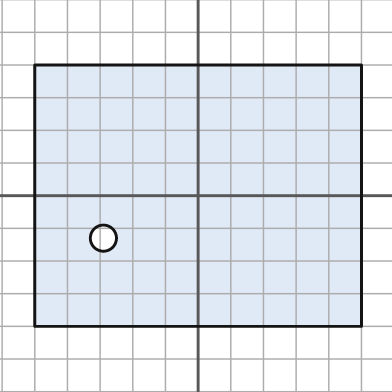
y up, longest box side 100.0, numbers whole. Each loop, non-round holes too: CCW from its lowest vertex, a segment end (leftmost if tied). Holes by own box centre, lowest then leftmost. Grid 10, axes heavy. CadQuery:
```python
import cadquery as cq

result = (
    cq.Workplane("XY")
    .moveTo(-50.0, -40.0)
    .lineTo(50.0, -40.0)
    .lineTo(50.0, 40.0)
    .lineTo(-50.0, 40.0)
    .close()
    .moveTo(-29.0, -13.0)
    .circle(4.0)
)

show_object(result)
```